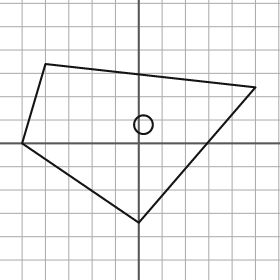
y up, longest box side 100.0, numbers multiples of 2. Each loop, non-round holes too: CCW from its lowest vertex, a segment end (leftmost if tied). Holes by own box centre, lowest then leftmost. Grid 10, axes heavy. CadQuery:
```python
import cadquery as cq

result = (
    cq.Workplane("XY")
    .moveTo(0.0, -34.0)
    .lineTo(50.0, 24.0)
    .lineTo(-40.0, 34.0)
    .lineTo(-50.0, 0.0)
    .close()
    .moveTo(2.0, 8.0)
    .circle(4.0)
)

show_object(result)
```